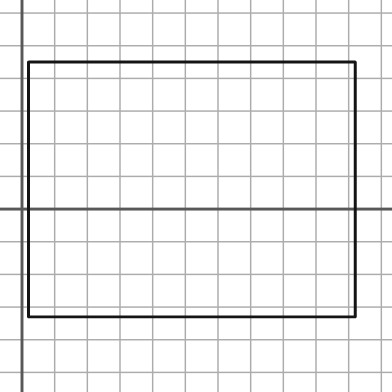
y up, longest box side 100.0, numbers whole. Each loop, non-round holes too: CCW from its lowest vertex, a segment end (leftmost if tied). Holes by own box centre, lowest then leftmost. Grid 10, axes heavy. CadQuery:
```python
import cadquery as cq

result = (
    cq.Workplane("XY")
    .moveTo(2.0, -33.0)
    .lineTo(102.0, -33.0)
    .lineTo(102.0, 45.0)
    .lineTo(2.0, 45.0)
    .close()
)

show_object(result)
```